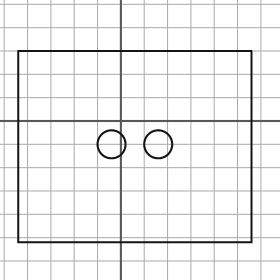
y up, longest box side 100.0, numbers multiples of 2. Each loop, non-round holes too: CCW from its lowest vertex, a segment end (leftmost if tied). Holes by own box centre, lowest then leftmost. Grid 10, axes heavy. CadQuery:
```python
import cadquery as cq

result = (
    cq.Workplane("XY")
    .moveTo(-44.0, -52.0)
    .lineTo(56.0, -52.0)
    .lineTo(56.0, 30.0)
    .lineTo(-44.0, 30.0)
    .close()
    .moveTo(-4.0, -10.0)
    .circle(6.0)
    .moveTo(16.0, -10.0)
    .circle(6.0)
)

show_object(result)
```